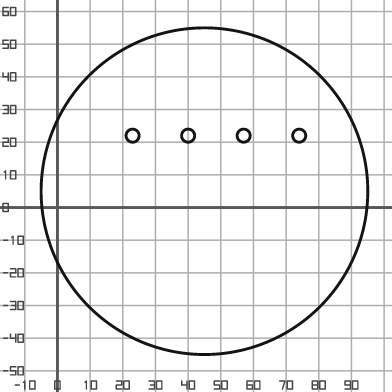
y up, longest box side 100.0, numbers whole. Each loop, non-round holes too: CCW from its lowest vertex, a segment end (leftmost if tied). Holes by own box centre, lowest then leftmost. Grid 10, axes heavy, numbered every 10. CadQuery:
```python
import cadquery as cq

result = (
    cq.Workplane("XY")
    .moveTo(45.0, 5.0)
    .circle(50.0)
    .moveTo(23.0, 22.0)
    .circle(2.0)
    .moveTo(40.0, 22.0)
    .circle(2.0)
    .moveTo(57.0, 22.0)
    .circle(2.0)
    .moveTo(74.0, 22.0)
    .circle(2.0)
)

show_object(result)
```